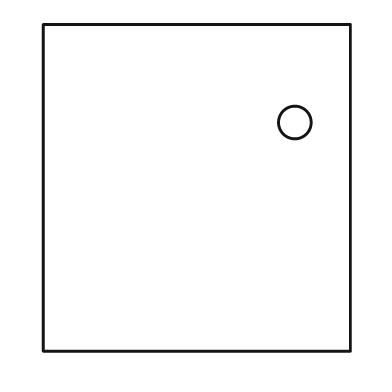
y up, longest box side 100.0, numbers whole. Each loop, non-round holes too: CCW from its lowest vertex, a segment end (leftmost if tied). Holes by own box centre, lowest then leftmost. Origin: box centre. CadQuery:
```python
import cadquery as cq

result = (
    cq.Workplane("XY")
    .moveTo(-47.0, -50.0)
    .lineTo(47.0, -50.0)
    .lineTo(47.0, 50.0)
    .lineTo(-47.0, 50.0)
    .close()
    .moveTo(30.0, 20.0)
    .circle(5.0)
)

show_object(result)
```